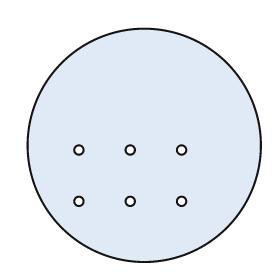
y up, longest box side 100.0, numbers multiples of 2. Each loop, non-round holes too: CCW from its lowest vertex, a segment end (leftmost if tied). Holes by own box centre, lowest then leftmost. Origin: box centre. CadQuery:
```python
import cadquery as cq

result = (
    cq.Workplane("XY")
    .moveTo(0.0, 0.0)
    .circle(50.0)
    .moveTo(-28.0, -24.0)
    .circle(2.0)
    .moveTo(-6.0, -24.0)
    .circle(2.0)
    .moveTo(16.0, -24.0)
    .circle(2.0)
    .moveTo(-28.0, -2.0)
    .circle(2.0)
    .moveTo(-6.0, -2.0)
    .circle(2.0)
    .moveTo(16.0, -2.0)
    .circle(2.0)
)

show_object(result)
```